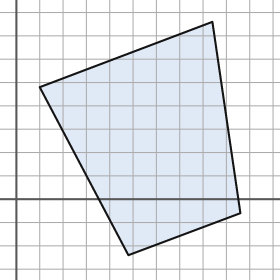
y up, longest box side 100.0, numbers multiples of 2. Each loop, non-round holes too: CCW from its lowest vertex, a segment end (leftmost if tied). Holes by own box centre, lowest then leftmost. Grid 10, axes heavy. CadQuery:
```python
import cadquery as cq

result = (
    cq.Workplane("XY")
    .moveTo(48.0, -24.0)
    .lineTo(96.0, -6.0)
    .lineTo(84.0, 76.0)
    .lineTo(10.0, 48.0)
    .close()
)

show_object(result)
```